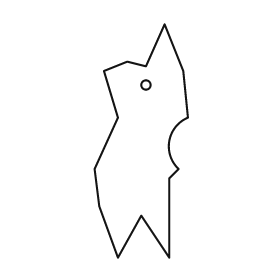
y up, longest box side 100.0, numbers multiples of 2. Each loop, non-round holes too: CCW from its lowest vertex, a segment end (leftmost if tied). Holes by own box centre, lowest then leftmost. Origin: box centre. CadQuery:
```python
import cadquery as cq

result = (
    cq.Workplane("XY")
    .moveTo(-10.0, -50.0)
    .lineTo(0.0, -32.0)
    .lineTo(12.0, -50.0)
    .lineTo(12.0, -16.0)
    .lineTo(16.0, -12.0)
    .threePointArc((12.0, 0.0), (20.0, 10.0))
    .lineTo(18.0, 30.0)
    .lineTo(10.0, 50.0)
    .lineTo(2.0, 32.0)
    .lineTo(-6.0, 34.0)
    .lineTo(-16.0, 30.0)
    .lineTo(-10.0, 10.0)
    .lineTo(-20.0, -12.0)
    .lineTo(-18.0, -28.0)
    .close()
    .moveTo(2.0, 24.0)
    .circle(2.0)
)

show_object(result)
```